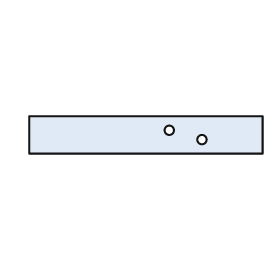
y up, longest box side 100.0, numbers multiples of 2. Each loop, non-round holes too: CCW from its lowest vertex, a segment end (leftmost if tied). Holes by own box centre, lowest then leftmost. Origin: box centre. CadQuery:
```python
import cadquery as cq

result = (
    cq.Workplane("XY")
    .moveTo(-50.0, -8.0)
    .lineTo(50.0, -8.0)
    .lineTo(50.0, 8.0)
    .lineTo(-50.0, 8.0)
    .close()
    .moveTo(24.0, -2.0)
    .circle(2.0)
    .moveTo(10.0, 2.0)
    .circle(2.0)
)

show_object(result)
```